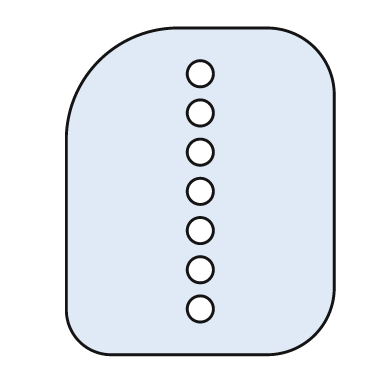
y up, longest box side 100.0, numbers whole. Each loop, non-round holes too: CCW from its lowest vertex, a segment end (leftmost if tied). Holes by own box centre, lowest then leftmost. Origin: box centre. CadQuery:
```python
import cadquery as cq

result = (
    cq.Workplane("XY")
    .moveTo(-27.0, -50.0)
    .lineTo(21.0, -50.0)
    .threePointArc((35.0, -44.0), (41.0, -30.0))
    .lineTo(41.0, 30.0)
    .threePointArc((35.0, 44.0), (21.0, 50.0))
    .lineTo(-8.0, 50.0)
    .threePointArc((-31.0, 40.0), (-41.0, 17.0))
    .lineTo(-41.0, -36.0)
    .threePointArc((-37.0, -46.0), (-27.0, -50.0))
    .close()
    .moveTo(0.0, -36.0)
    .circle(4.0)
    .moveTo(0.0, -24.0)
    .circle(4.0)
    .moveTo(0.0, -12.0)
    .circle(4.0)
    .moveTo(0.0, 0.0)
    .circle(4.0)
    .moveTo(0.0, 12.0)
    .circle(4.0)
    .moveTo(0.0, 24.0)
    .circle(4.0)
    .moveTo(0.0, 36.0)
    .circle(4.0)
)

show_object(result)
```